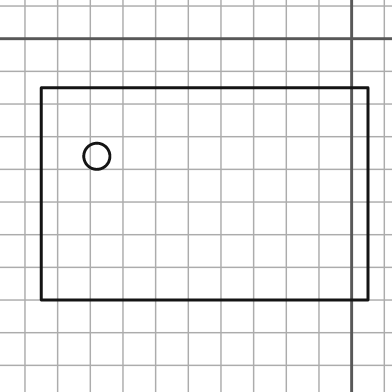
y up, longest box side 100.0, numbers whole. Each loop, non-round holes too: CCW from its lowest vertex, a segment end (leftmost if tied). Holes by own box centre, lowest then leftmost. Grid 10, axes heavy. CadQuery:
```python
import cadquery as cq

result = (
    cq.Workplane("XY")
    .moveTo(-95.0, -80.0)
    .lineTo(5.0, -80.0)
    .lineTo(5.0, -15.0)
    .lineTo(-95.0, -15.0)
    .close()
    .moveTo(-78.0, -36.0)
    .circle(4.0)
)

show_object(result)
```